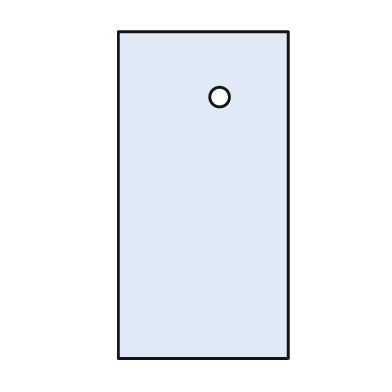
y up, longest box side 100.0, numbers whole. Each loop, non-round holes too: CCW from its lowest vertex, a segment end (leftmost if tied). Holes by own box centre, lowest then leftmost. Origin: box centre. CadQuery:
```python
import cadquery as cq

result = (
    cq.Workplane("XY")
    .moveTo(-26.0, -50.0)
    .lineTo(26.0, -50.0)
    .lineTo(26.0, 50.0)
    .lineTo(-26.0, 50.0)
    .close()
    .moveTo(5.0, 30.0)
    .circle(3.0)
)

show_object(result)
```